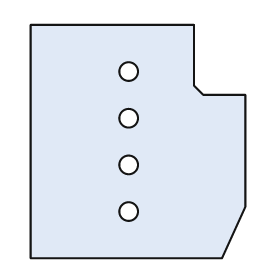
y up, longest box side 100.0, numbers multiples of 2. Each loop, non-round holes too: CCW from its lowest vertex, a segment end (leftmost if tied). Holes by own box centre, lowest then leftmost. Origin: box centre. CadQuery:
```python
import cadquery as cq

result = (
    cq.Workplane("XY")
    .moveTo(-46.0, -50.0)
    .lineTo(36.0, -50.0)
    .lineTo(46.0, -28.0)
    .lineTo(46.0, 20.0)
    .lineTo(28.0, 20.0)
    .lineTo(24.0, 24.0)
    .lineTo(24.0, 50.0)
    .lineTo(-46.0, 50.0)
    .close()
    .moveTo(-4.0, -30.0)
    .circle(4.0)
    .moveTo(-4.0, -10.0)
    .circle(4.0)
    .moveTo(-4.0, 10.0)
    .circle(4.0)
    .moveTo(-4.0, 30.0)
    .circle(4.0)
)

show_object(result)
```